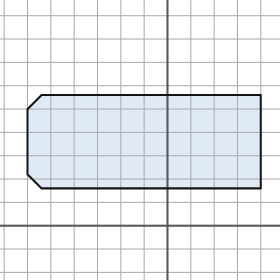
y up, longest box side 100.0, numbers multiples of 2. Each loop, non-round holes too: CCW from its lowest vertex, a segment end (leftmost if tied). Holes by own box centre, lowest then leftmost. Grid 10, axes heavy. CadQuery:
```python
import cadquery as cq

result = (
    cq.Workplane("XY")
    .moveTo(-54.0, 16.0)
    .lineTo(40.0, 16.0)
    .lineTo(40.0, 56.0)
    .lineTo(-54.0, 56.0)
    .lineTo(-60.0, 50.0)
    .lineTo(-60.0, 22.0)
    .close()
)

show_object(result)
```